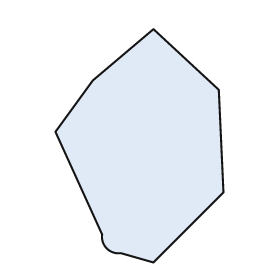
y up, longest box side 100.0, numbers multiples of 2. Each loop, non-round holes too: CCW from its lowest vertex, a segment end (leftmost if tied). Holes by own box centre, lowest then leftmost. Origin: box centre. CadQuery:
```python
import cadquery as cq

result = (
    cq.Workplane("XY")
    .moveTo(6.0, -50.0)
    .lineTo(36.0, -20.0)
    .lineTo(34.0, 24.0)
    .lineTo(6.0, 50.0)
    .lineTo(-20.0, 28.0)
    .lineTo(-36.0, 6.0)
    .lineTo(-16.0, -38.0)
    .threePointArc((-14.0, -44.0), (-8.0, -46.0))
    .close()
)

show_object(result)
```